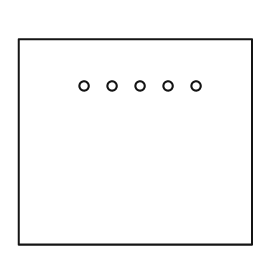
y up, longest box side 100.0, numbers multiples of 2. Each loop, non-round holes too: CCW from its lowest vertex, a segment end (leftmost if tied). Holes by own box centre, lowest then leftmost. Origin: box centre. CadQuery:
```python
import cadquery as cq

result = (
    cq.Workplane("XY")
    .moveTo(-50.0, -44.0)
    .lineTo(50.0, -44.0)
    .lineTo(50.0, 44.0)
    .lineTo(-50.0, 44.0)
    .close()
    .moveTo(-22.0, 24.0)
    .circle(2.0)
    .moveTo(-10.0, 24.0)
    .circle(2.0)
    .moveTo(2.0, 24.0)
    .circle(2.0)
    .moveTo(14.0, 24.0)
    .circle(2.0)
    .moveTo(26.0, 24.0)
    .circle(2.0)
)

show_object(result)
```